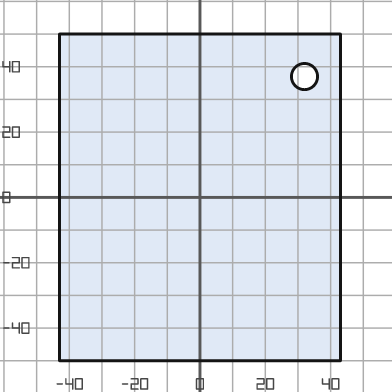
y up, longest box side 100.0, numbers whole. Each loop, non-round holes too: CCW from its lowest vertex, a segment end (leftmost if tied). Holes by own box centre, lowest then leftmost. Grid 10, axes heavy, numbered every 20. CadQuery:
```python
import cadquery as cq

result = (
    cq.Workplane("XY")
    .moveTo(-43.0, -50.0)
    .lineTo(43.0, -50.0)
    .lineTo(43.0, 50.0)
    .lineTo(-43.0, 50.0)
    .close()
    .moveTo(32.0, 37.0)
    .circle(4.0)
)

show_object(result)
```